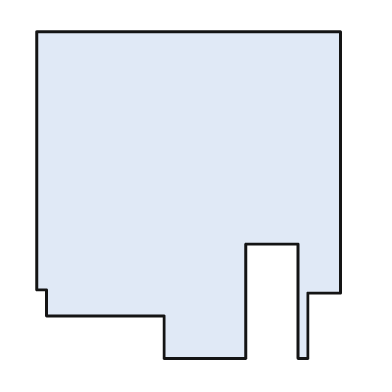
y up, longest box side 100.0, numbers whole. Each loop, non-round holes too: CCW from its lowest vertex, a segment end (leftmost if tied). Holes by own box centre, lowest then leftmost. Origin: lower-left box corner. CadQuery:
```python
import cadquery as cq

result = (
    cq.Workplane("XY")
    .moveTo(39.0, 0.0)
    .lineTo(64.0, 0.0)
    .lineTo(64.0, 35.0)
    .lineTo(80.0, 35.0)
    .lineTo(80.0, 0.0)
    .lineTo(83.0, 0.0)
    .lineTo(83.0, 20.0)
    .lineTo(93.0, 20.0)
    .lineTo(93.0, 100.0)
    .lineTo(0.0, 100.0)
    .lineTo(0.0, 21.0)
    .lineTo(3.0, 21.0)
    .lineTo(3.0, 13.0)
    .lineTo(39.0, 13.0)
    .close()
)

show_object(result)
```